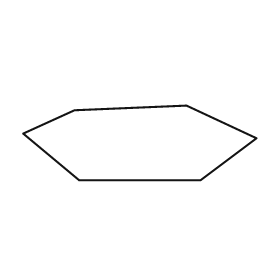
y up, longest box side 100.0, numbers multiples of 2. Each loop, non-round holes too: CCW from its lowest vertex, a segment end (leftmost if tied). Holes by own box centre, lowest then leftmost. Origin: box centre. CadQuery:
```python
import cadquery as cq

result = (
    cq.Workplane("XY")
    .moveTo(-26.0, -16.0)
    .lineTo(26.0, -16.0)
    .lineTo(50.0, 2.0)
    .lineTo(20.0, 16.0)
    .lineTo(-28.0, 14.0)
    .lineTo(-50.0, 4.0)
    .close()
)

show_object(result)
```